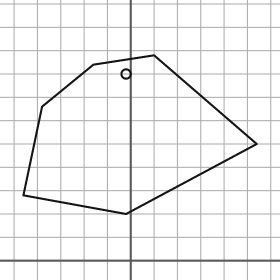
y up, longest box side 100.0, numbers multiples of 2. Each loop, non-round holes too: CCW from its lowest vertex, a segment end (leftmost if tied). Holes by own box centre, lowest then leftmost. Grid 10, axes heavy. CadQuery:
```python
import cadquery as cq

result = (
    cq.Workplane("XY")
    .moveTo(-2.0, 20.0)
    .lineTo(54.0, 50.0)
    .lineTo(10.0, 88.0)
    .lineTo(-16.0, 84.0)
    .lineTo(-38.0, 66.0)
    .lineTo(-46.0, 28.0)
    .close()
    .moveTo(-2.0, 80.0)
    .circle(2.0)
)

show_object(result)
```